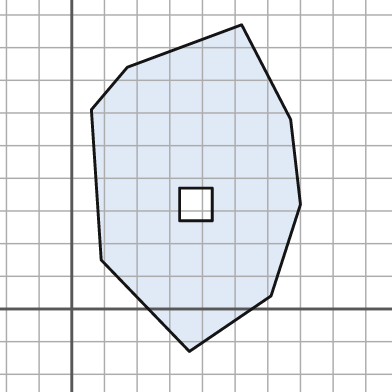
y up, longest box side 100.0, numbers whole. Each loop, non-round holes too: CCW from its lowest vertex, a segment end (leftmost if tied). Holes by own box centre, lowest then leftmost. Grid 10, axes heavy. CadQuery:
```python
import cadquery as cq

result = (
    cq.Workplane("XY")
    .moveTo(36.0, -13.0)
    .lineTo(61.0, 4.0)
    .lineTo(70.0, 32.0)
    .lineTo(67.0, 58.0)
    .lineTo(52.0, 87.0)
    .lineTo(17.0, 74.0)
    .lineTo(6.0, 61.0)
    .lineTo(9.0, 15.0)
    .close()
    .moveTo(33.0, 27.0)
    .lineTo(43.0, 27.0)
    .lineTo(43.0, 37.0)
    .lineTo(33.0, 37.0)
    .close()
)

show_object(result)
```